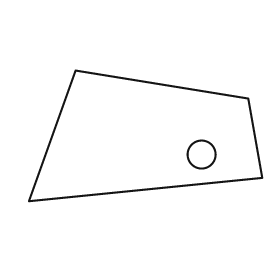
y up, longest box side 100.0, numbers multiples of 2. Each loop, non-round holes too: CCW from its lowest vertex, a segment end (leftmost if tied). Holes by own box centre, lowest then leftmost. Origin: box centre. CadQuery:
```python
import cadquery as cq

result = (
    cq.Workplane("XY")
    .moveTo(-50.0, -28.0)
    .lineTo(50.0, -18.0)
    .lineTo(44.0, 16.0)
    .lineTo(-30.0, 28.0)
    .close()
    .moveTo(24.0, -8.0)
    .circle(6.0)
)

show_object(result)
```